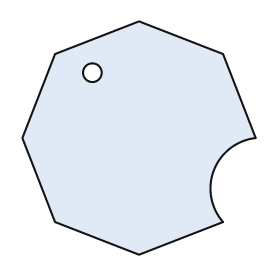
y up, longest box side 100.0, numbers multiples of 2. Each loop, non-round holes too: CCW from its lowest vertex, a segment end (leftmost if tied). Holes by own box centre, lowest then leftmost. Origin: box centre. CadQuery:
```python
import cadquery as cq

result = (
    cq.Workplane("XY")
    .moveTo(0.0, -50.0)
    .lineTo(36.0, -36.0)
    .threePointArc((32.0, -14.0), (50.0, 0.0))
    .lineTo(36.0, 36.0)
    .lineTo(0.0, 50.0)
    .lineTo(-36.0, 36.0)
    .lineTo(-50.0, 0.0)
    .lineTo(-36.0, -36.0)
    .close()
    .moveTo(-20.0, 28.0)
    .circle(4.0)
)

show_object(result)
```